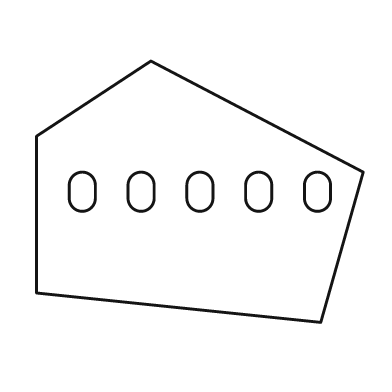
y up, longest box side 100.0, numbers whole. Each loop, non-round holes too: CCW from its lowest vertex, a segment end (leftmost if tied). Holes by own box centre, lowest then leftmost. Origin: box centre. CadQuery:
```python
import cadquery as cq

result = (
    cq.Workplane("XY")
    .moveTo(37.0, -40.0)
    .lineTo(50.0, 6.0)
    .lineTo(-15.0, 40.0)
    .lineTo(-50.0, 17.0)
    .lineTo(-50.0, -31.0)
    .close()
    .moveTo(-40.0, -2.0)
    .threePointArc((-36.0, -6.0), (-32.0, -2.0))
    .lineTo(-32.0, 2.0)
    .threePointArc((-36.0, 6.0), (-40.0, 2.0))
    .close()
    .moveTo(-22.0, -2.0)
    .threePointArc((-18.0, -6.0), (-14.0, -2.0))
    .lineTo(-14.0, 2.0)
    .threePointArc((-18.0, 6.0), (-22.0, 2.0))
    .close()
    .moveTo(-4.0, -2.0)
    .threePointArc((0.0, -6.0), (4.0, -2.0))
    .lineTo(4.0, 2.0)
    .threePointArc((0.0, 6.0), (-4.0, 2.0))
    .close()
    .moveTo(14.0, -2.0)
    .threePointArc((18.0, -6.0), (22.0, -2.0))
    .lineTo(22.0, 2.0)
    .threePointArc((18.0, 6.0), (14.0, 2.0))
    .close()
    .moveTo(32.0, -2.0)
    .threePointArc((36.0, -6.0), (40.0, -2.0))
    .lineTo(40.0, 2.0)
    .threePointArc((36.0, 6.0), (32.0, 2.0))
    .close()
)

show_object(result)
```